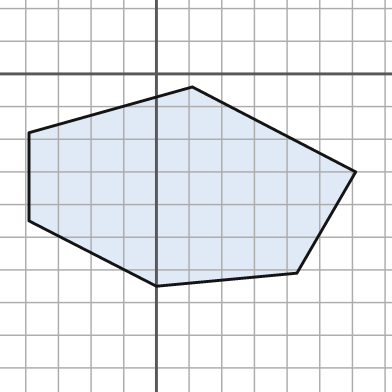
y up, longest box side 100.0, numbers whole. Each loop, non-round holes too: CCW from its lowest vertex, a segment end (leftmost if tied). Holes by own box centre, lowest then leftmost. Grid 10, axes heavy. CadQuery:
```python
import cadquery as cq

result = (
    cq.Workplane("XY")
    .moveTo(0.0, -65.0)
    .lineTo(43.0, -61.0)
    .lineTo(61.0, -30.0)
    .lineTo(11.0, -4.0)
    .lineTo(-39.0, -18.0)
    .lineTo(-39.0, -45.0)
    .close()
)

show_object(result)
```